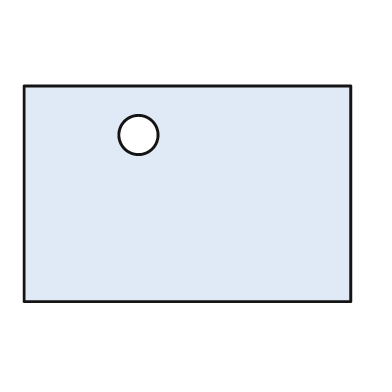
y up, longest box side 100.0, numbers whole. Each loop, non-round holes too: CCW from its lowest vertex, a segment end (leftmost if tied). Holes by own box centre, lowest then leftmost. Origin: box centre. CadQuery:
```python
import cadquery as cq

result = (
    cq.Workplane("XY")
    .moveTo(-50.0, -33.0)
    .lineTo(50.0, -33.0)
    .lineTo(50.0, 33.0)
    .lineTo(-50.0, 33.0)
    .close()
    .moveTo(-15.0, 18.0)
    .circle(6.0)
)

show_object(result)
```